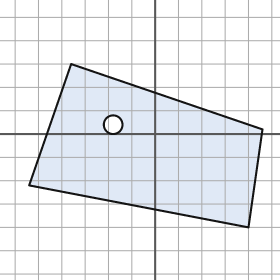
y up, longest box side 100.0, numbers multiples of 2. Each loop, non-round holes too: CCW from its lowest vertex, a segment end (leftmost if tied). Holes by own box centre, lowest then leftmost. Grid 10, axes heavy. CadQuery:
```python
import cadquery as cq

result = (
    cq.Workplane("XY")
    .moveTo(40.0, -40.0)
    .lineTo(46.0, 2.0)
    .lineTo(-36.0, 30.0)
    .lineTo(-54.0, -22.0)
    .close()
    .moveTo(-18.0, 4.0)
    .circle(4.0)
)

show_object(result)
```